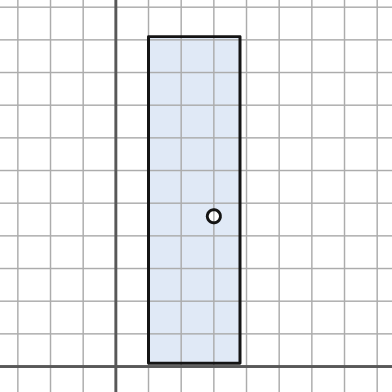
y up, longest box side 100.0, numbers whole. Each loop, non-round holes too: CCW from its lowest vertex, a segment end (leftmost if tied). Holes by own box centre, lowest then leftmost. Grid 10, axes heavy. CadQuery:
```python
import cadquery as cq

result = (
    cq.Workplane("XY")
    .moveTo(10.0, 1.0)
    .lineTo(38.0, 1.0)
    .lineTo(38.0, 101.0)
    .lineTo(10.0, 101.0)
    .close()
    .moveTo(30.0, 46.0)
    .circle(2.0)
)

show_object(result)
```